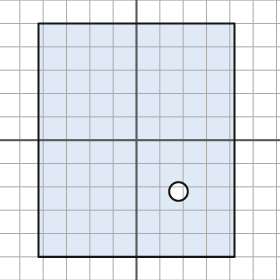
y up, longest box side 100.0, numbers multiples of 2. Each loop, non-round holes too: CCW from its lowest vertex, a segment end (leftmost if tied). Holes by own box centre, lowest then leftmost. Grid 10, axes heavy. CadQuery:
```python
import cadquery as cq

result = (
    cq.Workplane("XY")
    .moveTo(-42.0, -50.0)
    .lineTo(42.0, -50.0)
    .lineTo(42.0, 50.0)
    .lineTo(-42.0, 50.0)
    .close()
    .moveTo(18.0, -22.0)
    .circle(4.0)
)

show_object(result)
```